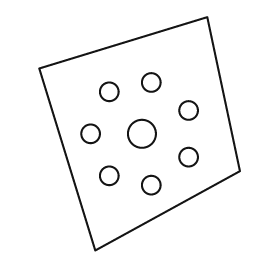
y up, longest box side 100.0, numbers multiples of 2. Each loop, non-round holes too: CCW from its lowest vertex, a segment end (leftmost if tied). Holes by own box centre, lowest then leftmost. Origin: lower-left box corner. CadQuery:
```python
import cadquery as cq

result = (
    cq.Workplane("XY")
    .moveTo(24.0, 0.0)
    .lineTo(86.0, 34.0)
    .lineTo(72.0, 100.0)
    .lineTo(0.0, 78.0)
    .close()
    .moveTo(48.0, 28.0)
    .circle(4.0)
    .moveTo(30.0, 32.0)
    .circle(4.0)
    .moveTo(64.0, 40.0)
    .circle(4.0)
    .moveTo(22.0, 50.0)
    .circle(4.0)
    .moveTo(44.0, 50.0)
    .circle(6.0)
    .moveTo(64.0, 60.0)
    .circle(4.0)
    .moveTo(30.0, 68.0)
    .circle(4.0)
    .moveTo(48.0, 72.0)
    .circle(4.0)
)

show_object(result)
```